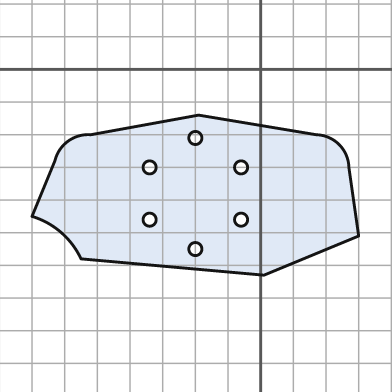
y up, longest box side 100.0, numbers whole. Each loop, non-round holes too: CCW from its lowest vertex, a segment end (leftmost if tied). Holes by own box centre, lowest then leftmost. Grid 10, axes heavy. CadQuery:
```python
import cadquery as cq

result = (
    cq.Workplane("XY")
    .moveTo(1.0, -63.0)
    .lineTo(30.0, -51.0)
    .lineTo(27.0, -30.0)
    .threePointArc((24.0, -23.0), (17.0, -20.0))
    .lineTo(-19.0, -14.0)
    .lineTo(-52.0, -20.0)
    .threePointArc((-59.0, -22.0), (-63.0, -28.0))
    .lineTo(-70.0, -45.0)
    .threePointArc((-61.0, -50.0), (-55.0, -58.0))
    .close()
    .moveTo(-20.0, -55.0)
    .circle(2.0)
    .moveTo(-34.0, -46.0)
    .circle(2.0)
    .moveTo(-6.0, -46.0)
    .circle(2.0)
    .moveTo(-34.0, -30.0)
    .circle(2.0)
    .moveTo(-6.0, -30.0)
    .circle(2.0)
    .moveTo(-20.0, -21.0)
    .circle(2.0)
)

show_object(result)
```